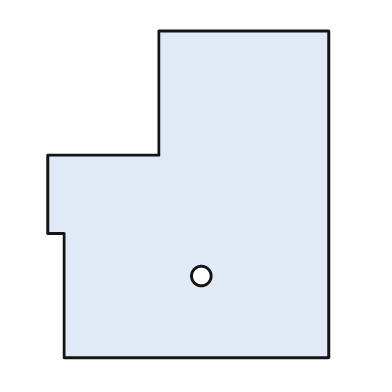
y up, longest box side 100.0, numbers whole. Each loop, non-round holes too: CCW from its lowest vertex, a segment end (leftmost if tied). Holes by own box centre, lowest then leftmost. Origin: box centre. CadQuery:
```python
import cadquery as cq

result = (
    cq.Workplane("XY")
    .moveTo(-38.0, -50.0)
    .lineTo(43.0, -50.0)
    .lineTo(43.0, 50.0)
    .lineTo(-9.0, 50.0)
    .lineTo(-9.0, 12.0)
    .lineTo(-43.0, 12.0)
    .lineTo(-43.0, -12.0)
    .lineTo(-38.0, -12.0)
    .close()
    .moveTo(4.0, -25.0)
    .circle(3.0)
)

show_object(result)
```